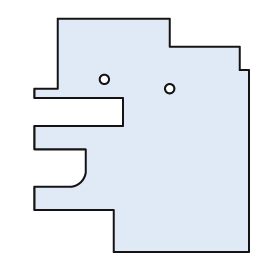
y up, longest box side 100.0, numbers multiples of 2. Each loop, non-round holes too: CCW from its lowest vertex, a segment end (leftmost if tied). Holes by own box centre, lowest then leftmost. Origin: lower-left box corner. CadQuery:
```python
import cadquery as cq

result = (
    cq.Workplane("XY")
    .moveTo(34.0, 0.0)
    .lineTo(92.0, 0.0)
    .lineTo(92.0, 78.0)
    .lineTo(88.0, 78.0)
    .lineTo(88.0, 88.0)
    .lineTo(58.0, 88.0)
    .lineTo(58.0, 100.0)
    .lineTo(10.0, 100.0)
    .lineTo(10.0, 70.0)
    .lineTo(0.0, 70.0)
    .lineTo(0.0, 66.0)
    .lineTo(38.0, 66.0)
    .lineTo(38.0, 54.0)
    .lineTo(0.0, 54.0)
    .lineTo(0.0, 44.0)
    .lineTo(22.0, 44.0)
    .lineTo(22.0, 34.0)
    .threePointArc((20.0, 30.0), (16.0, 28.0))
    .lineTo(0.0, 28.0)
    .lineTo(0.0, 18.0)
    .lineTo(34.0, 18.0)
    .close()
    .moveTo(58.0, 70.0)
    .circle(2.0)
    .moveTo(30.0, 74.0)
    .circle(2.0)
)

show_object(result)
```